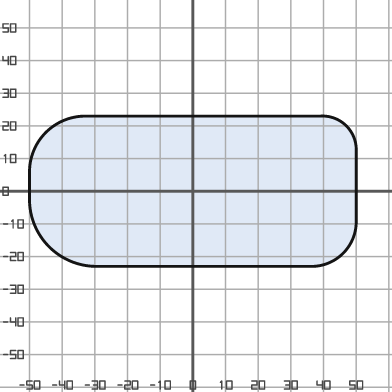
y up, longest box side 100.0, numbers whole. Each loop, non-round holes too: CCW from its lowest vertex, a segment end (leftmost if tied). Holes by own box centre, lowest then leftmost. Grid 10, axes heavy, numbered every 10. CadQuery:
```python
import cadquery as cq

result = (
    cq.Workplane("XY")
    .moveTo(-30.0, -23.0)
    .lineTo(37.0, -23.0)
    .threePointArc((46.0, -19.0), (50.0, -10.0))
    .lineTo(50.0, 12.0)
    .threePointArc((47.0, 20.0), (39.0, 23.0))
    .lineTo(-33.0, 23.0)
    .threePointArc((-45.0, 18.0), (-50.0, 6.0))
    .lineTo(-50.0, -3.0)
    .threePointArc((-44.0, -17.0), (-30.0, -23.0))
    .close()
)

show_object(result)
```